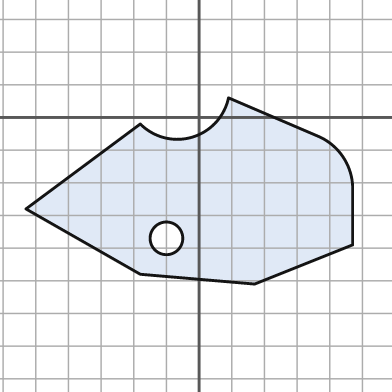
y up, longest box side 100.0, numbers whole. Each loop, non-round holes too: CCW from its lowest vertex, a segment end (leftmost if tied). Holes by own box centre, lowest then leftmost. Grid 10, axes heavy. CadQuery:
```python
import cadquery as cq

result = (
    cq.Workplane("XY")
    .moveTo(17.0, -51.0)
    .lineTo(47.0, -39.0)
    .lineTo(47.0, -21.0)
    .threePointArc((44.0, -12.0), (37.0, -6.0))
    .lineTo(9.0, 6.0)
    .threePointArc((-2.0, -6.0), (-18.0, -2.0))
    .lineTo(-53.0, -28.0)
    .lineTo(-18.0, -48.0)
    .close()
    .moveTo(-10.0, -37.0)
    .circle(5.0)
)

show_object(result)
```